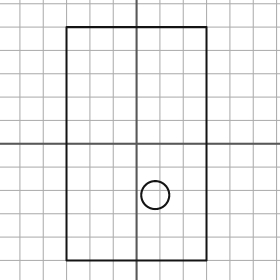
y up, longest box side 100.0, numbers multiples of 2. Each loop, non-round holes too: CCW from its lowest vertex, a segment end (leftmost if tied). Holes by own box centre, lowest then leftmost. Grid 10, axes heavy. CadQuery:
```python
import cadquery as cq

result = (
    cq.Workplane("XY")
    .moveTo(-30.0, -50.0)
    .lineTo(30.0, -50.0)
    .lineTo(30.0, 50.0)
    .lineTo(-30.0, 50.0)
    .close()
    .moveTo(8.0, -22.0)
    .circle(6.0)
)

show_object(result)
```